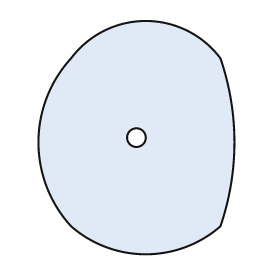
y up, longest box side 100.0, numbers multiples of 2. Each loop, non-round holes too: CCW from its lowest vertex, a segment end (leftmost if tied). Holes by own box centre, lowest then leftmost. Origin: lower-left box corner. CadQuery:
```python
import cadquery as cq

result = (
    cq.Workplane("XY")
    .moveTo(14.0, 12.0)
    .threePointArc((46.0, 0.0), (78.0, 12.0))
    .threePointArc((84.0, 48.0), (78.0, 84.0))
    .threePointArc((46.0, 100.0), (14.0, 84.0))
    .threePointArc((0.0, 48.0), (14.0, 12.0))
    .close()
    .moveTo(42.0, 50.0)
    .circle(4.0)
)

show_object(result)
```